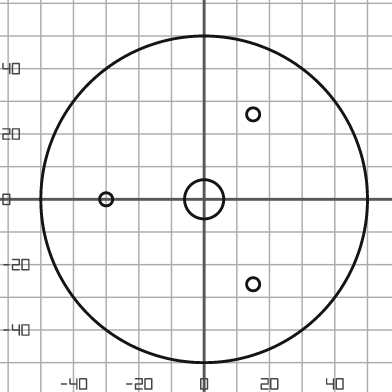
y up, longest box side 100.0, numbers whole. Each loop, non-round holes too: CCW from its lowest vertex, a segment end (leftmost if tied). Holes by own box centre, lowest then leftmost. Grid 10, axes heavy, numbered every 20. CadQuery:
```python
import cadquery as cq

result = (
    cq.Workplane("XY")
    .moveTo(0.0, 0.0)
    .circle(50.0)
    .moveTo(15.0, -26.0)
    .circle(2.0)
    .moveTo(-30.0, 0.0)
    .circle(2.0)
    .moveTo(0.0, 0.0)
    .circle(6.0)
    .moveTo(15.0, 26.0)
    .circle(2.0)
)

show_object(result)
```